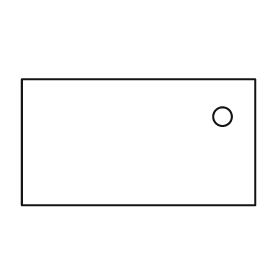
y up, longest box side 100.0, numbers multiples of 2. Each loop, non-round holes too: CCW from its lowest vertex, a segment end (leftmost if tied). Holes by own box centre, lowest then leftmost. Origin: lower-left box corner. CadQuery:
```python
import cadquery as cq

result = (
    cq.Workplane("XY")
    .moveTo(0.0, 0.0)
    .lineTo(100.0, 0.0)
    .lineTo(100.0, 54.0)
    .lineTo(0.0, 54.0)
    .close()
    .moveTo(86.0, 38.0)
    .circle(4.0)
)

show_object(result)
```